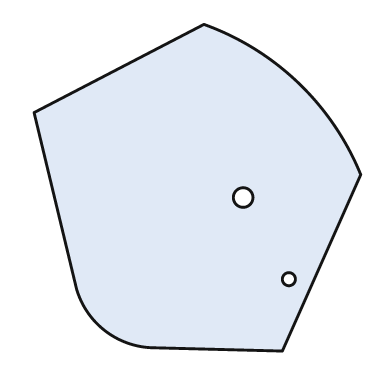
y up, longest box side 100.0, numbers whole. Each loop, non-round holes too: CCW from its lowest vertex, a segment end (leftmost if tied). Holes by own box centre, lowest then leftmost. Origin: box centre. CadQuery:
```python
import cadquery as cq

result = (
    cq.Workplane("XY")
    .moveTo(26.0, -50.0)
    .lineTo(50.0, 4.0)
    .threePointArc((31.0, 32.0), (2.0, 50.0))
    .lineTo(-50.0, 23.0)
    .lineTo(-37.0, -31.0)
    .threePointArc((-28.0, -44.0), (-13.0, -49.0))
    .close()
    .moveTo(28.0, -28.0)
    .circle(2.0)
    .moveTo(14.0, -3.0)
    .circle(3.0)
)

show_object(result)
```